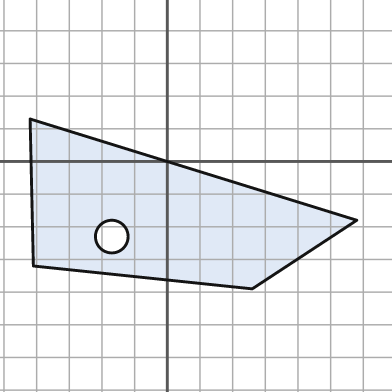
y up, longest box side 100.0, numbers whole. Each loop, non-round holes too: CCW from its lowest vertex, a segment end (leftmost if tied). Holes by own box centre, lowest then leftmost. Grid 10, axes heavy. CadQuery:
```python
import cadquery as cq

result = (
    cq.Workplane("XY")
    .moveTo(26.0, -39.0)
    .lineTo(58.0, -18.0)
    .lineTo(-42.0, 13.0)
    .lineTo(-41.0, -32.0)
    .close()
    .moveTo(-17.0, -23.0)
    .circle(5.0)
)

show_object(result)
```